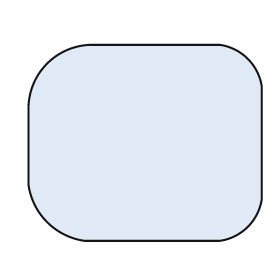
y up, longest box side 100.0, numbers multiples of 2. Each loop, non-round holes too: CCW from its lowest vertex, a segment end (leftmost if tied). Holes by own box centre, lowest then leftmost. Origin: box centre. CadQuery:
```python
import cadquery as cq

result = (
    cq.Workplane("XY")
    .moveTo(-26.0, -42.0)
    .lineTo(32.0, -42.0)
    .threePointArc((44.0, -36.0), (50.0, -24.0))
    .lineTo(50.0, 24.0)
    .threePointArc((44.0, 36.0), (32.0, 42.0))
    .lineTo(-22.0, 42.0)
    .threePointArc((-42.0, 34.0), (-50.0, 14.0))
    .lineTo(-50.0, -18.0)
    .threePointArc((-42.0, -34.0), (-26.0, -42.0))
    .close()
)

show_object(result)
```